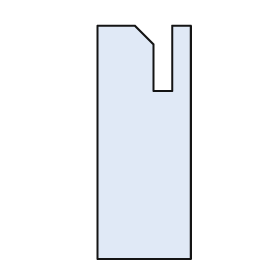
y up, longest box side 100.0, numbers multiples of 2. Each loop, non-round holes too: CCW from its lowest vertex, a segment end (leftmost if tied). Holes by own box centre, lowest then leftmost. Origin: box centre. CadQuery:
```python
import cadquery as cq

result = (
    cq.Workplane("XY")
    .moveTo(-20.0, -50.0)
    .lineTo(20.0, -50.0)
    .lineTo(20.0, 50.0)
    .lineTo(12.0, 50.0)
    .lineTo(12.0, 22.0)
    .lineTo(4.0, 22.0)
    .lineTo(4.0, 42.0)
    .lineTo(-4.0, 50.0)
    .lineTo(-20.0, 50.0)
    .close()
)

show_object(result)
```